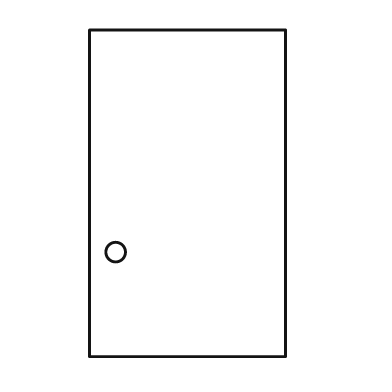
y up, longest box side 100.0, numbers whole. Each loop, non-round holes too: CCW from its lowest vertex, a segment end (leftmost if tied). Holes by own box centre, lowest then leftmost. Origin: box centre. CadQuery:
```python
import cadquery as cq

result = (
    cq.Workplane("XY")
    .moveTo(-30.0, -50.0)
    .lineTo(30.0, -50.0)
    .lineTo(30.0, 50.0)
    .lineTo(-30.0, 50.0)
    .close()
    .moveTo(-22.0, -18.0)
    .circle(3.0)
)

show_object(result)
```